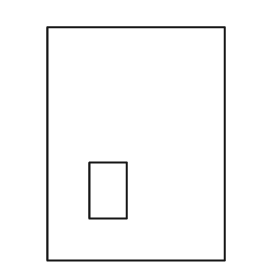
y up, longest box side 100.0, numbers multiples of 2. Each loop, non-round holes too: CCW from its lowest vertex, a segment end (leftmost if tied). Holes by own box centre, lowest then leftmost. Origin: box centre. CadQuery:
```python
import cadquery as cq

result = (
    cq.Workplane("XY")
    .moveTo(-38.0, -50.0)
    .lineTo(38.0, -50.0)
    .lineTo(38.0, 50.0)
    .lineTo(-38.0, 50.0)
    .close()
    .moveTo(-20.0, -32.0)
    .lineTo(-4.0, -32.0)
    .lineTo(-4.0, -8.0)
    .lineTo(-20.0, -8.0)
    .close()
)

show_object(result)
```